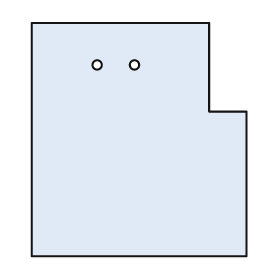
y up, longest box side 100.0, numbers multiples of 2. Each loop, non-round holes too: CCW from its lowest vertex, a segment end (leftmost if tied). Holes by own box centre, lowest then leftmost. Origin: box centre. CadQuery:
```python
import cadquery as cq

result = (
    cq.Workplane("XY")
    .moveTo(-46.0, -50.0)
    .lineTo(46.0, -50.0)
    .lineTo(46.0, 12.0)
    .lineTo(30.0, 12.0)
    .lineTo(30.0, 50.0)
    .lineTo(-46.0, 50.0)
    .close()
    .moveTo(-18.0, 32.0)
    .circle(2.0)
    .moveTo(-2.0, 32.0)
    .circle(2.0)
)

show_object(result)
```